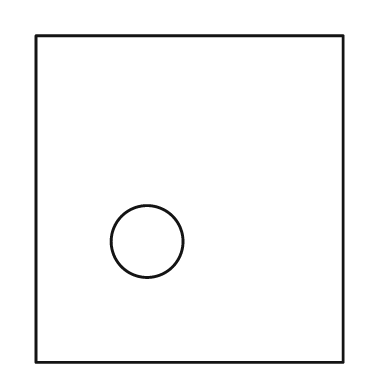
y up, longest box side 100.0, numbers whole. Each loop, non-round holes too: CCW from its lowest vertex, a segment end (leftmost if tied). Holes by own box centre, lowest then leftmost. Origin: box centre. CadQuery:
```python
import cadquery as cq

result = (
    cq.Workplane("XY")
    .moveTo(-47.0, -50.0)
    .lineTo(47.0, -50.0)
    .lineTo(47.0, 50.0)
    .lineTo(-47.0, 50.0)
    .close()
    .moveTo(-13.0, -13.0)
    .circle(11.0)
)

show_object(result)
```